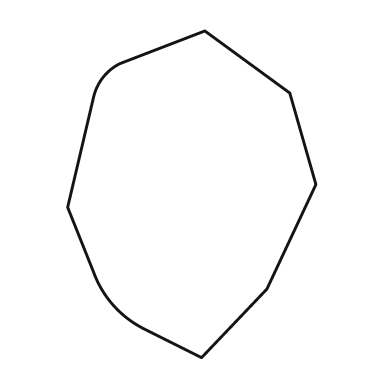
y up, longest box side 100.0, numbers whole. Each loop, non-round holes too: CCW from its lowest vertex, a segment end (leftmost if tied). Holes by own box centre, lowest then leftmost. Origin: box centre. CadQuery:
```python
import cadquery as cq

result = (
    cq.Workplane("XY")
    .moveTo(3.0, -50.0)
    .lineTo(23.0, -29.0)
    .lineTo(38.0, 3.0)
    .lineTo(30.0, 31.0)
    .lineTo(4.0, 50.0)
    .lineTo(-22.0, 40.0)
    .threePointArc((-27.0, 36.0), (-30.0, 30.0))
    .lineTo(-38.0, -4.0)
    .lineTo(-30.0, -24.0)
    .threePointArc((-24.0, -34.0), (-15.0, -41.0))
    .close()
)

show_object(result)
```